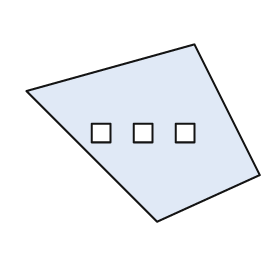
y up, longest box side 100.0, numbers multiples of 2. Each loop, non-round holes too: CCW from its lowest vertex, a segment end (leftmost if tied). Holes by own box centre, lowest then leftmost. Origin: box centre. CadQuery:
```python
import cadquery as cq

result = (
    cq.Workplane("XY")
    .moveTo(6.0, -38.0)
    .lineTo(50.0, -18.0)
    .lineTo(22.0, 38.0)
    .lineTo(-50.0, 18.0)
    .close()
    .moveTo(-22.0, -4.0)
    .lineTo(-14.0, -4.0)
    .lineTo(-14.0, 4.0)
    .lineTo(-22.0, 4.0)
    .close()
    .moveTo(-4.0, -4.0)
    .lineTo(4.0, -4.0)
    .lineTo(4.0, 4.0)
    .lineTo(-4.0, 4.0)
    .close()
    .moveTo(14.0, -4.0)
    .lineTo(22.0, -4.0)
    .lineTo(22.0, 4.0)
    .lineTo(14.0, 4.0)
    .close()
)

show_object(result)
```